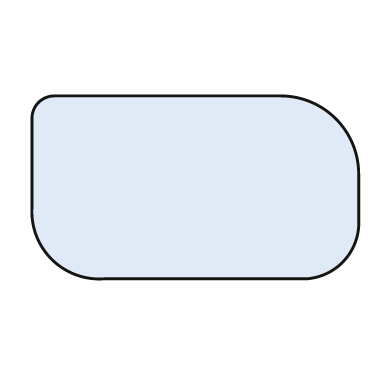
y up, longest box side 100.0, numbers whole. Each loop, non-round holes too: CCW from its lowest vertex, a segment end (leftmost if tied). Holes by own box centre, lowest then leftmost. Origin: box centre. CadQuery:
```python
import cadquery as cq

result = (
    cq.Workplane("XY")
    .moveTo(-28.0, -28.0)
    .lineTo(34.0, -28.0)
    .threePointArc((45.0, -23.0), (50.0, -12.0))
    .lineTo(50.0, 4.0)
    .threePointArc((43.0, 21.0), (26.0, 28.0))
    .lineTo(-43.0, 28.0)
    .threePointArc((-48.0, 26.0), (-50.0, 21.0))
    .lineTo(-50.0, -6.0)
    .threePointArc((-44.0, -22.0), (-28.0, -28.0))
    .close()
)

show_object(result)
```